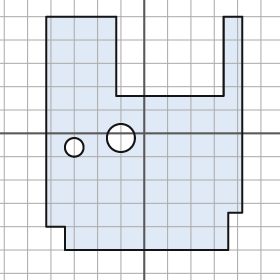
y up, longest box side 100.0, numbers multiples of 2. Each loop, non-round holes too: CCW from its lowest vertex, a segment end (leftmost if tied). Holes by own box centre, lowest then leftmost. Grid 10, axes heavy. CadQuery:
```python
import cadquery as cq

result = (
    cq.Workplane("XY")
    .moveTo(-34.0, -50.0)
    .lineTo(36.0, -50.0)
    .lineTo(36.0, -34.0)
    .lineTo(42.0, -34.0)
    .lineTo(42.0, 50.0)
    .lineTo(34.0, 50.0)
    .lineTo(34.0, 16.0)
    .lineTo(-12.0, 16.0)
    .lineTo(-12.0, 50.0)
    .lineTo(-42.0, 50.0)
    .lineTo(-42.0, -40.0)
    .lineTo(-34.0, -40.0)
    .close()
    .moveTo(-30.0, -6.0)
    .circle(4.0)
    .moveTo(-10.0, -2.0)
    .circle(6.0)
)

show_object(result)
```